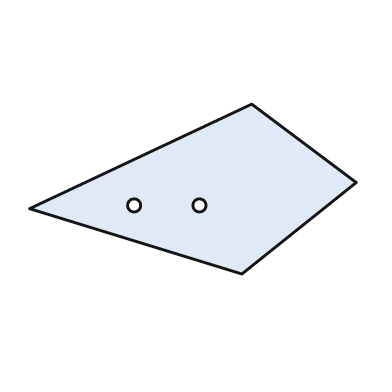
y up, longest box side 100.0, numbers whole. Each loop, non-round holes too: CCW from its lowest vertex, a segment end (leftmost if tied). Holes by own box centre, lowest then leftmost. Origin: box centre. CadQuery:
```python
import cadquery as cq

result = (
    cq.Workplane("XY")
    .moveTo(15.0, -26.0)
    .lineTo(50.0, 2.0)
    .lineTo(18.0, 26.0)
    .lineTo(-50.0, -6.0)
    .close()
    .moveTo(-18.0, -5.0)
    .circle(2.0)
    .moveTo(2.0, -5.0)
    .circle(2.0)
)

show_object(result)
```